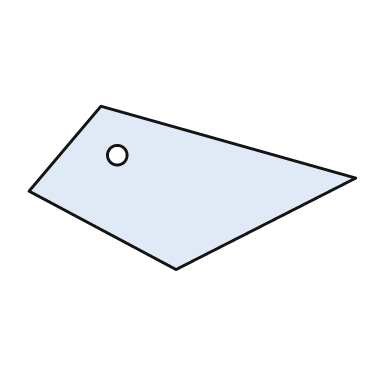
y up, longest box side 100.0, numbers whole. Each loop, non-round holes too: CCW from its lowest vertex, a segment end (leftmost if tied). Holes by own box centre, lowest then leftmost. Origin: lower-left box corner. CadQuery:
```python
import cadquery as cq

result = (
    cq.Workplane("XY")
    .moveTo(45.0, 0.0)
    .lineTo(100.0, 28.0)
    .lineTo(22.0, 50.0)
    .lineTo(0.0, 24.0)
    .close()
    .moveTo(27.0, 35.0)
    .circle(3.0)
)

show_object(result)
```